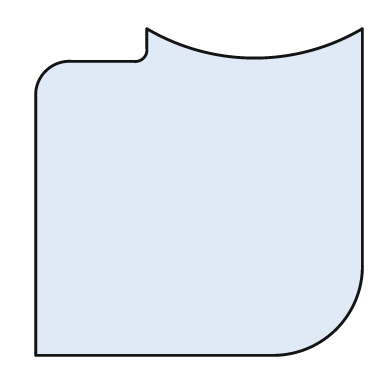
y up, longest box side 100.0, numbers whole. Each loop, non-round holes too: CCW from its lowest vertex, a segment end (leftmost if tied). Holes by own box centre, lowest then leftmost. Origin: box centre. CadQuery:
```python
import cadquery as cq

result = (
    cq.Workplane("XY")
    .moveTo(-50.0, -50.0)
    .lineTo(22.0, -50.0)
    .threePointArc((42.0, -42.0), (50.0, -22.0))
    .lineTo(50.0, 50.0)
    .threePointArc((17.0, 41.0), (-16.0, 50.0))
    .lineTo(-16.0, 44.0)
    .threePointArc((-17.0, 41.0), (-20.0, 40.0))
    .lineTo(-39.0, 40.0)
    .threePointArc((-47.0, 37.0), (-50.0, 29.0))
    .close()
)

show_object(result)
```